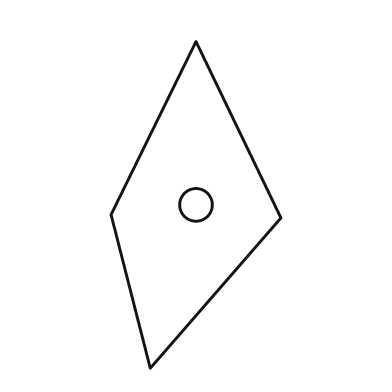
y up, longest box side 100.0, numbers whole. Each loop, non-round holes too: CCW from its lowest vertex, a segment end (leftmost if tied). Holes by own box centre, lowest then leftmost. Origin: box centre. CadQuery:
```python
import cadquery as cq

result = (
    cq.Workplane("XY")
    .moveTo(-14.0, -50.0)
    .lineTo(26.0, -4.0)
    .lineTo(0.0, 50.0)
    .lineTo(-26.0, -3.0)
    .close()
    .moveTo(0.0, 0.0)
    .circle(5.0)
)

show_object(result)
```